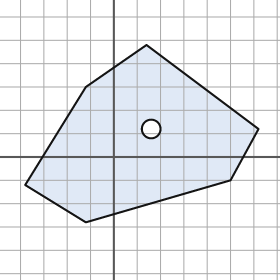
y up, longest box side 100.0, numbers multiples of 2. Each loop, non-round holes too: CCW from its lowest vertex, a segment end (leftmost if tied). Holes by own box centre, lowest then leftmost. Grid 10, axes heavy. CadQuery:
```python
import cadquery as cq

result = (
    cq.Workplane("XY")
    .moveTo(-12.0, -28.0)
    .lineTo(50.0, -10.0)
    .lineTo(62.0, 12.0)
    .lineTo(14.0, 48.0)
    .lineTo(-12.0, 30.0)
    .lineTo(-38.0, -12.0)
    .close()
    .moveTo(16.0, 12.0)
    .circle(4.0)
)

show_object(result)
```